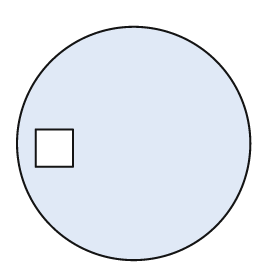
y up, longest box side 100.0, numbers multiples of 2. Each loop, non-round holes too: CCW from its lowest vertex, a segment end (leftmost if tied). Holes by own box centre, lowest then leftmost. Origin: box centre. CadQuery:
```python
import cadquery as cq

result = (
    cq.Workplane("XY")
    .moveTo(0.0, 0.0)
    .circle(50.0)
    .moveTo(-42.0, -10.0)
    .lineTo(-26.0, -10.0)
    .lineTo(-26.0, 6.0)
    .lineTo(-42.0, 6.0)
    .close()
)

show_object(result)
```